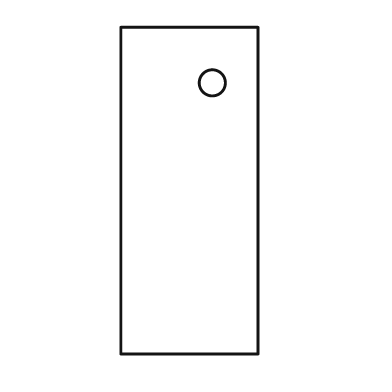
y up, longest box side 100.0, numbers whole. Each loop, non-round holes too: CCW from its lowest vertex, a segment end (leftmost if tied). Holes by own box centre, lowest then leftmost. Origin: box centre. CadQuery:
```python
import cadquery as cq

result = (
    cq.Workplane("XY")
    .moveTo(-21.0, -50.0)
    .lineTo(21.0, -50.0)
    .lineTo(21.0, 50.0)
    .lineTo(-21.0, 50.0)
    .close()
    .moveTo(7.0, 33.0)
    .circle(4.0)
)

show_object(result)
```